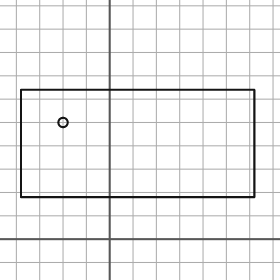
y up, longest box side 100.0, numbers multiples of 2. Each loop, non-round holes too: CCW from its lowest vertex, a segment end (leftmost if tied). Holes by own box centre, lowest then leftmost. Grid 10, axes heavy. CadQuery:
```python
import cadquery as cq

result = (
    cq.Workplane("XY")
    .moveTo(-38.0, 18.0)
    .lineTo(62.0, 18.0)
    .lineTo(62.0, 64.0)
    .lineTo(-38.0, 64.0)
    .close()
    .moveTo(-20.0, 50.0)
    .circle(2.0)
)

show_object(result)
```